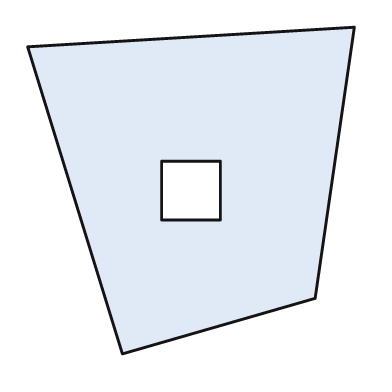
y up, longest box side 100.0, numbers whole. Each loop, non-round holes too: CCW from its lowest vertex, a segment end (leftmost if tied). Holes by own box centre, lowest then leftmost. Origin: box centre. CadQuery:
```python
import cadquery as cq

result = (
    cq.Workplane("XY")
    .moveTo(-21.0, -50.0)
    .lineTo(38.0, -33.0)
    .lineTo(50.0, 50.0)
    .lineTo(-50.0, 44.0)
    .close()
    .moveTo(-9.0, -9.0)
    .lineTo(9.0, -9.0)
    .lineTo(9.0, 9.0)
    .lineTo(-9.0, 9.0)
    .close()
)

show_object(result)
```